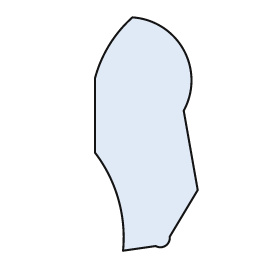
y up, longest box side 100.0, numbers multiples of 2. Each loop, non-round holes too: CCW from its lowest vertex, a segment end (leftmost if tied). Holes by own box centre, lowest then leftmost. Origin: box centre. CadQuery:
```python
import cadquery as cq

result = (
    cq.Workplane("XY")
    .moveTo(-10.0, -50.0)
    .lineTo(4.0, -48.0)
    .threePointArc((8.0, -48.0), (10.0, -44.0))
    .lineTo(22.0, -24.0)
    .lineTo(16.0, 10.0)
    .threePointArc((16.0, 36.0), (-6.0, 50.0))
    .threePointArc((-16.0, 38.0), (-22.0, 24.0))
    .lineTo(-22.0, -8.0)
    .threePointArc((-12.0, -28.0), (-10.0, -50.0))
    .close()
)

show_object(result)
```